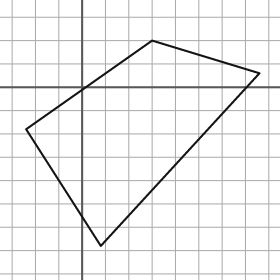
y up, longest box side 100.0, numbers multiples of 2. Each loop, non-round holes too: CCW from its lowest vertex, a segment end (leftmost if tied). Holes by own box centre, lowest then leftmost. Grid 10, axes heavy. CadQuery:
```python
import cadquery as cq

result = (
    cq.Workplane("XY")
    .moveTo(8.0, -68.0)
    .lineTo(76.0, 6.0)
    .lineTo(30.0, 20.0)
    .lineTo(-24.0, -18.0)
    .close()
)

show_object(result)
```